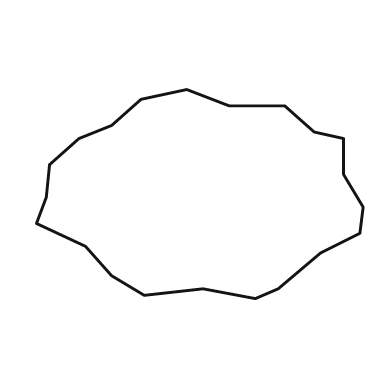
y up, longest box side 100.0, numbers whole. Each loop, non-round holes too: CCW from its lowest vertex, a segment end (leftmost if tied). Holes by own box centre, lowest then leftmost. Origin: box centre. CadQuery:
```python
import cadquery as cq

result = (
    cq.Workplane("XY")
    .moveTo(17.0, -32.0)
    .lineTo(24.0, -29.0)
    .lineTo(37.0, -18.0)
    .lineTo(49.0, -12.0)
    .lineTo(50.0, -4.0)
    .lineTo(44.0, 6.0)
    .lineTo(44.0, 17.0)
    .lineTo(35.0, 19.0)
    .lineTo(26.0, 27.0)
    .lineTo(9.0, 27.0)
    .lineTo(-4.0, 32.0)
    .lineTo(-18.0, 29.0)
    .lineTo(-27.0, 21.0)
    .lineTo(-37.0, 17.0)
    .lineTo(-46.0, 9.0)
    .lineTo(-47.0, -1.0)
    .lineTo(-50.0, -9.0)
    .lineTo(-35.0, -16.0)
    .lineTo(-27.0, -25.0)
    .lineTo(-17.0, -31.0)
    .lineTo(1.0, -29.0)
    .close()
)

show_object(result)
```